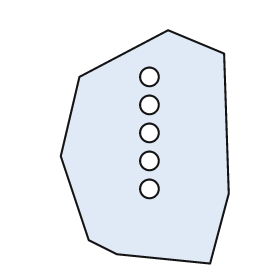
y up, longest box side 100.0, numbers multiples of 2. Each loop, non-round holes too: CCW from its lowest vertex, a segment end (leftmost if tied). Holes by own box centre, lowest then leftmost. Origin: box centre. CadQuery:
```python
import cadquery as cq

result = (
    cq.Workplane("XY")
    .moveTo(28.0, -50.0)
    .lineTo(36.0, -20.0)
    .lineTo(34.0, 40.0)
    .lineTo(10.0, 50.0)
    .lineTo(-28.0, 30.0)
    .lineTo(-36.0, -4.0)
    .lineTo(-24.0, -40.0)
    .lineTo(-12.0, -46.0)
    .close()
    .moveTo(2.0, -18.0)
    .circle(4.0)
    .moveTo(2.0, -6.0)
    .circle(4.0)
    .moveTo(2.0, 6.0)
    .circle(4.0)
    .moveTo(2.0, 18.0)
    .circle(4.0)
    .moveTo(2.0, 30.0)
    .circle(4.0)
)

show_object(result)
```